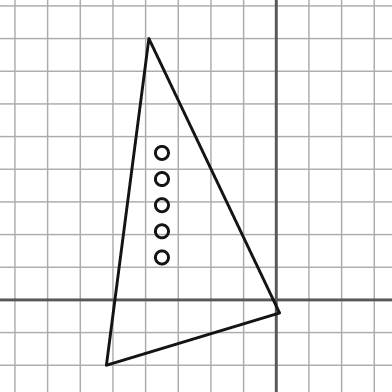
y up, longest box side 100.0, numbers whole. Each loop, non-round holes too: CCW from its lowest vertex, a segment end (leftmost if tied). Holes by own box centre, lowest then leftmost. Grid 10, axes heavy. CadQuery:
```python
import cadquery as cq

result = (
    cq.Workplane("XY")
    .moveTo(-52.0, -20.0)
    .lineTo(1.0, -4.0)
    .lineTo(-39.0, 80.0)
    .close()
    .moveTo(-35.0, 13.0)
    .circle(2.0)
    .moveTo(-35.0, 21.0)
    .circle(2.0)
    .moveTo(-35.0, 29.0)
    .circle(2.0)
    .moveTo(-35.0, 37.0)
    .circle(2.0)
    .moveTo(-35.0, 45.0)
    .circle(2.0)
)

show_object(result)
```